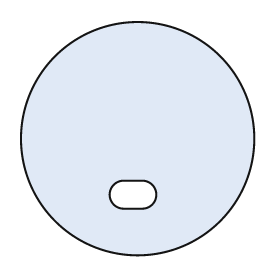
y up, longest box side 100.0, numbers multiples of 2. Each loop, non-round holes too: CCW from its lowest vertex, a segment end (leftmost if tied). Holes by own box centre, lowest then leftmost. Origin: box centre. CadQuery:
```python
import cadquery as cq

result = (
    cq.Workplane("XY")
    .moveTo(0.0, 0.0)
    .circle(50.0)
    .moveTo(-6.0, -30.0)
    .lineTo(2.0, -30.0)
    .threePointArc((8.0, -24.0), (2.0, -18.0))
    .lineTo(-6.0, -18.0)
    .threePointArc((-12.0, -24.0), (-6.0, -30.0))
    .close()
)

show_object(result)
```